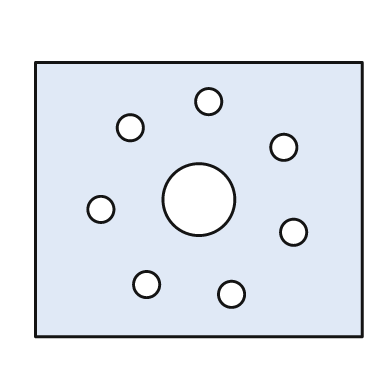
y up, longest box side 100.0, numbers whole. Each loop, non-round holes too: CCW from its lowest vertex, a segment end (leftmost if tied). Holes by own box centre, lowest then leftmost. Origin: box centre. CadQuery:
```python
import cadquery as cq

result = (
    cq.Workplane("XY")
    .moveTo(-50.0, -42.0)
    .lineTo(50.0, -42.0)
    .lineTo(50.0, 42.0)
    .lineTo(-50.0, 42.0)
    .close()
    .moveTo(10.0, -29.0)
    .circle(4.0)
    .moveTo(-16.0, -26.0)
    .circle(4.0)
    .moveTo(29.0, -10.0)
    .circle(4.0)
    .moveTo(-30.0, -3.0)
    .circle(4.0)
    .moveTo(0.0, 0.0)
    .circle(11.0)
    .moveTo(26.0, 16.0)
    .circle(4.0)
    .moveTo(-21.0, 22.0)
    .circle(4.0)
    .moveTo(3.0, 30.0)
    .circle(4.0)
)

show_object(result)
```